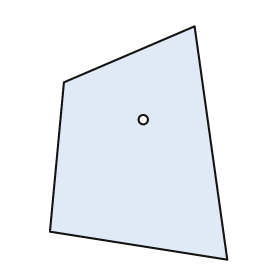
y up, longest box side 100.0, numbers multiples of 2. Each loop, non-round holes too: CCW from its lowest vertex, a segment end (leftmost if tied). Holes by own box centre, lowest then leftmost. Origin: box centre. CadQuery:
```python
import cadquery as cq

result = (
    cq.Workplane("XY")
    .moveTo(38.0, -50.0)
    .lineTo(24.0, 50.0)
    .lineTo(-32.0, 26.0)
    .lineTo(-38.0, -38.0)
    .close()
    .moveTo(2.0, 10.0)
    .circle(2.0)
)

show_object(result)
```